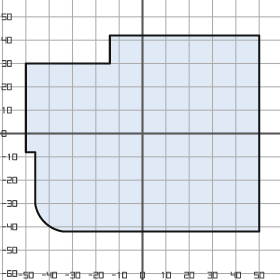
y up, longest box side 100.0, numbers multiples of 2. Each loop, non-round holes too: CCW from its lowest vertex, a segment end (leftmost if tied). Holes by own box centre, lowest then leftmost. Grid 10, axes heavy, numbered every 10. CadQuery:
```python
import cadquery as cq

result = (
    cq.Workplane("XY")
    .moveTo(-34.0, -42.0)
    .lineTo(50.0, -42.0)
    .lineTo(50.0, 42.0)
    .lineTo(-14.0, 42.0)
    .lineTo(-14.0, 30.0)
    .lineTo(-50.0, 30.0)
    .lineTo(-50.0, -8.0)
    .lineTo(-46.0, -8.0)
    .lineTo(-46.0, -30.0)
    .threePointArc((-42.0, -38.0), (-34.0, -42.0))
    .close()
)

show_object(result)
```